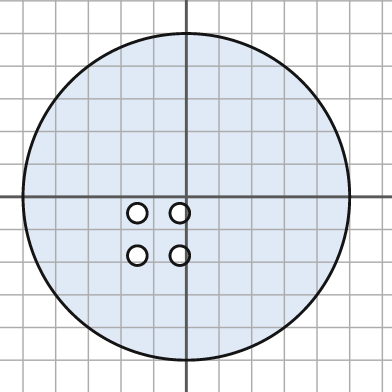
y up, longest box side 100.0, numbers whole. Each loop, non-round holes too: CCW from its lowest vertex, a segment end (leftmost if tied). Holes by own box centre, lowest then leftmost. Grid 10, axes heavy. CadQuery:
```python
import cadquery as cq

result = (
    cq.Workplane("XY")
    .moveTo(0.0, 0.0)
    .circle(50.0)
    .moveTo(-15.0, -18.0)
    .circle(3.0)
    .moveTo(-2.0, -18.0)
    .circle(3.0)
    .moveTo(-15.0, -5.0)
    .circle(3.0)
    .moveTo(-2.0, -5.0)
    .circle(3.0)
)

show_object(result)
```